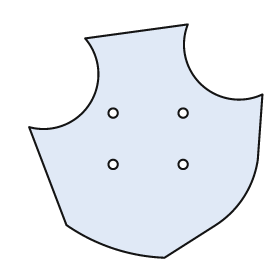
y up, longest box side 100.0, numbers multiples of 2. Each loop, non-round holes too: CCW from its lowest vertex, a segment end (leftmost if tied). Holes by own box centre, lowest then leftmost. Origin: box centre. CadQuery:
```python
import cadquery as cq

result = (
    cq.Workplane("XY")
    .moveTo(8.0, -50.0)
    .lineTo(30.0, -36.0)
    .threePointArc((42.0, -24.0), (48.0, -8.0))
    .lineTo(50.0, 20.0)
    .threePointArc((24.0, 24.0), (18.0, 50.0))
    .lineTo(-26.0, 44.0)
    .threePointArc((-24.0, 16.0), (-50.0, 6.0))
    .lineTo(-34.0, -36.0)
    .threePointArc((-14.0, -46.0), (8.0, -50.0))
    .close()
    .moveTo(-14.0, -10.0)
    .circle(2.0)
    .moveTo(16.0, -10.0)
    .circle(2.0)
    .moveTo(-14.0, 12.0)
    .circle(2.0)
    .moveTo(16.0, 12.0)
    .circle(2.0)
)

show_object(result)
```